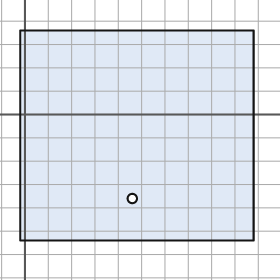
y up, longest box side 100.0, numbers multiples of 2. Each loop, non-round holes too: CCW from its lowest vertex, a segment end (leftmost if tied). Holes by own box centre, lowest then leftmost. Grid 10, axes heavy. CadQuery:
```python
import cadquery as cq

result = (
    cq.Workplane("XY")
    .moveTo(-2.0, -54.0)
    .lineTo(98.0, -54.0)
    .lineTo(98.0, 36.0)
    .lineTo(-2.0, 36.0)
    .close()
    .moveTo(46.0, -36.0)
    .circle(2.0)
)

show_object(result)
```